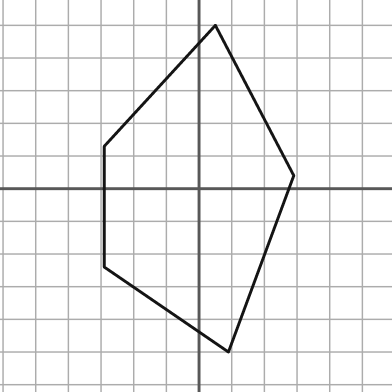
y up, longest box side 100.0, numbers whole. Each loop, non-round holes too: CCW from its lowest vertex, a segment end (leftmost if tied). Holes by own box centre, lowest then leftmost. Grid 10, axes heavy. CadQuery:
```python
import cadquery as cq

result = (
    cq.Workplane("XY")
    .moveTo(9.0, -50.0)
    .lineTo(29.0, 4.0)
    .lineTo(5.0, 50.0)
    .lineTo(-29.0, 13.0)
    .lineTo(-29.0, -24.0)
    .close()
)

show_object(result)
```